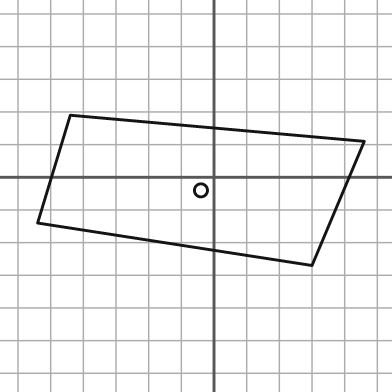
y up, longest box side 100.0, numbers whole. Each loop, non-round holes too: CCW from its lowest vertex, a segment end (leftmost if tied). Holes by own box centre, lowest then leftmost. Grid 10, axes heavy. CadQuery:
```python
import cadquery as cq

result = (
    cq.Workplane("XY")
    .moveTo(30.0, -27.0)
    .lineTo(46.0, 11.0)
    .lineTo(-44.0, 19.0)
    .lineTo(-54.0, -14.0)
    .close()
    .moveTo(-4.0, -4.0)
    .circle(2.0)
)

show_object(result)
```